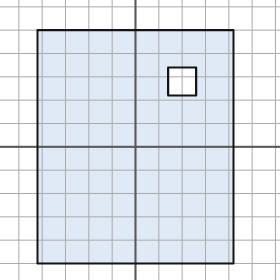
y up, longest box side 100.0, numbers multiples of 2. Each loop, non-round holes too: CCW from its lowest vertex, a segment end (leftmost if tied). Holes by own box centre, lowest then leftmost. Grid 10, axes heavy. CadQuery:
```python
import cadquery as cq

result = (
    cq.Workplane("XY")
    .moveTo(-42.0, -50.0)
    .lineTo(42.0, -50.0)
    .lineTo(42.0, 50.0)
    .lineTo(-42.0, 50.0)
    .close()
    .moveTo(14.0, 22.0)
    .lineTo(26.0, 22.0)
    .lineTo(26.0, 34.0)
    .lineTo(14.0, 34.0)
    .close()
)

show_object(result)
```